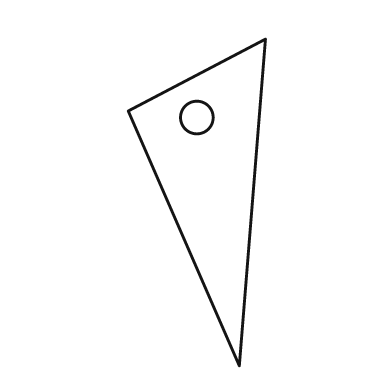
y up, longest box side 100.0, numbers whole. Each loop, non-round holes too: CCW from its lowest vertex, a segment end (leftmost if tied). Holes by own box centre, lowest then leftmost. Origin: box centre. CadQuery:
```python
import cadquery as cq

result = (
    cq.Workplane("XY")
    .moveTo(13.0, -50.0)
    .lineTo(21.0, 50.0)
    .lineTo(-21.0, 28.0)
    .close()
    .moveTo(0.0, 26.0)
    .circle(5.0)
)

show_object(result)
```